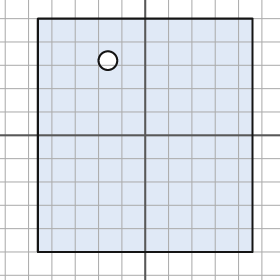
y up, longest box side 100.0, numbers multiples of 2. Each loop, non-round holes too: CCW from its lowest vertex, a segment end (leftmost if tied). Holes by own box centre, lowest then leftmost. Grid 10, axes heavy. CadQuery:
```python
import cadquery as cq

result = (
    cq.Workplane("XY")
    .moveTo(-46.0, -50.0)
    .lineTo(46.0, -50.0)
    .lineTo(46.0, 50.0)
    .lineTo(-46.0, 50.0)
    .close()
    .moveTo(-16.0, 32.0)
    .circle(4.0)
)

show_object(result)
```